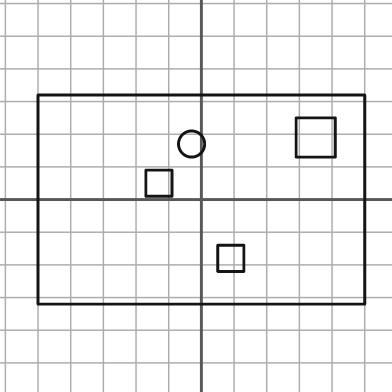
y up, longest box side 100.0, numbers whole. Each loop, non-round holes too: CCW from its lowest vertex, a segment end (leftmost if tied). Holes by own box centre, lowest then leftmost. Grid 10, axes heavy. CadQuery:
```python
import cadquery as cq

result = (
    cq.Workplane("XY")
    .moveTo(-50.0, -32.0)
    .lineTo(50.0, -32.0)
    .lineTo(50.0, 32.0)
    .lineTo(-50.0, 32.0)
    .close()
    .moveTo(5.0, -22.0)
    .lineTo(13.0, -22.0)
    .lineTo(13.0, -14.0)
    .lineTo(5.0, -14.0)
    .close()
    .moveTo(-17.0, 1.0)
    .lineTo(-9.0, 1.0)
    .lineTo(-9.0, 9.0)
    .lineTo(-17.0, 9.0)
    .close()
    .moveTo(-3.0, 17.0)
    .circle(4.0)
    .moveTo(29.0, 13.0)
    .lineTo(41.0, 13.0)
    .lineTo(41.0, 25.0)
    .lineTo(29.0, 25.0)
    .close()
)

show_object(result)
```